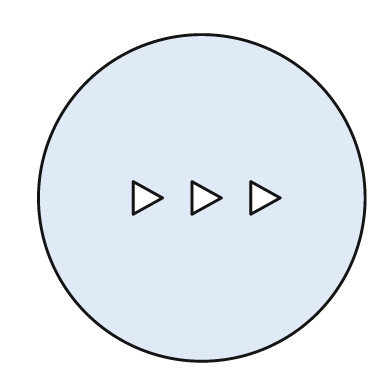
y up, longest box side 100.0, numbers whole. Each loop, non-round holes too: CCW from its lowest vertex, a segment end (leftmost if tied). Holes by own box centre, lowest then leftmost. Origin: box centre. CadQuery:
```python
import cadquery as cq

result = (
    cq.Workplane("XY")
    .moveTo(0.0, 0.0)
    .circle(50.0)
    .moveTo(-21.0, -5.0)
    .lineTo(-12.0, 0.0)
    .lineTo(-21.0, 5.0)
    .close()
    .moveTo(-3.0, -5.0)
    .lineTo(6.0, 0.0)
    .lineTo(-3.0, 5.0)
    .close()
    .moveTo(15.0, -5.0)
    .lineTo(24.0, 0.0)
    .lineTo(15.0, 5.0)
    .close()
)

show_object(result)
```